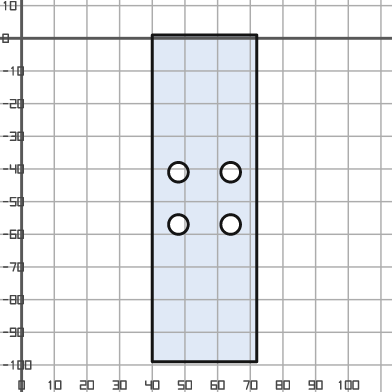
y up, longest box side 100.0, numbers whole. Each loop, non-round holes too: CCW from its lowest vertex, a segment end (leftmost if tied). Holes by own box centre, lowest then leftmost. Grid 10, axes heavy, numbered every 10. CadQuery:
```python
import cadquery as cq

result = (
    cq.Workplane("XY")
    .moveTo(40.0, -99.0)
    .lineTo(72.0, -99.0)
    .lineTo(72.0, 1.0)
    .lineTo(40.0, 1.0)
    .close()
    .moveTo(48.0, -57.0)
    .circle(3.0)
    .moveTo(64.0, -57.0)
    .circle(3.0)
    .moveTo(48.0, -41.0)
    .circle(3.0)
    .moveTo(64.0, -41.0)
    .circle(3.0)
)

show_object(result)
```